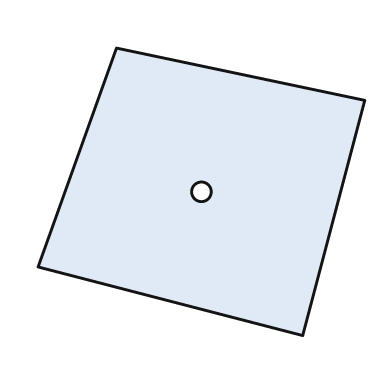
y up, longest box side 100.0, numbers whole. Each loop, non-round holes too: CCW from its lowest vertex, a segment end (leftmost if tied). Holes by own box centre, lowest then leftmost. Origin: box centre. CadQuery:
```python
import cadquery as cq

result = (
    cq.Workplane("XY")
    .moveTo(31.0, -44.0)
    .lineTo(50.0, 28.0)
    .lineTo(-26.0, 44.0)
    .lineTo(-50.0, -23.0)
    .close()
    .moveTo(0.0, 0.0)
    .circle(3.0)
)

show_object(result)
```